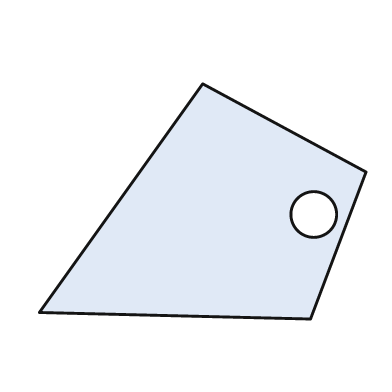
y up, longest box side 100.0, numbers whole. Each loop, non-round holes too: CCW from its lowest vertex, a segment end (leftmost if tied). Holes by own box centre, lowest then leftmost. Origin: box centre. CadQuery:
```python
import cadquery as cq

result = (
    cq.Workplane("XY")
    .moveTo(33.0, -36.0)
    .lineTo(50.0, 9.0)
    .lineTo(0.0, 36.0)
    .lineTo(-50.0, -34.0)
    .close()
    .moveTo(34.0, -4.0)
    .circle(7.0)
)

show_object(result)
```